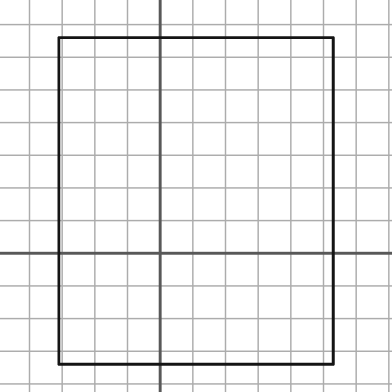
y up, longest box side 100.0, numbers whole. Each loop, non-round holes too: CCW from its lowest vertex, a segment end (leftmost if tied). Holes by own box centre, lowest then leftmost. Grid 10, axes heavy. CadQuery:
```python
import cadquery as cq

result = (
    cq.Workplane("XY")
    .moveTo(-31.0, -34.0)
    .lineTo(53.0, -34.0)
    .lineTo(53.0, 66.0)
    .lineTo(-31.0, 66.0)
    .close()
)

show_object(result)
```